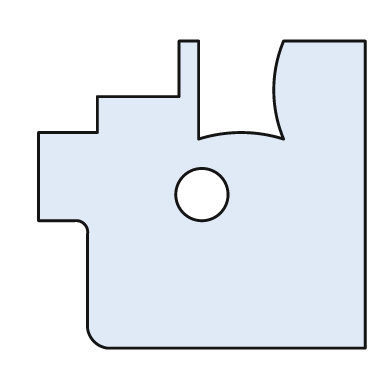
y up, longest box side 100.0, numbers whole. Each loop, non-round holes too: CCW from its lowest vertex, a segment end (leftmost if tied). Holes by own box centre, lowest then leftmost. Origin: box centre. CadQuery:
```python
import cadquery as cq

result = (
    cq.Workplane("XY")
    .moveTo(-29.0, -47.0)
    .lineTo(50.0, -47.0)
    .lineTo(50.0, 47.0)
    .lineTo(25.0, 47.0)
    .threePointArc((22.0, 32.0), (25.0, 17.0))
    .threePointArc((12.0, 19.0), (-1.0, 17.0))
    .lineTo(-1.0, 47.0)
    .lineTo(-7.0, 47.0)
    .lineTo(-7.0, 30.0)
    .lineTo(-32.0, 30.0)
    .lineTo(-32.0, 19.0)
    .lineTo(-50.0, 19.0)
    .lineTo(-50.0, -8.0)
    .lineTo(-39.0, -8.0)
    .threePointArc((-36.0, -9.0), (-35.0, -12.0))
    .lineTo(-35.0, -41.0)
    .threePointArc((-33.0, -45.0), (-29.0, -47.0))
    .close()
    .moveTo(0.0, 0.0)
    .circle(8.0)
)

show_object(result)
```